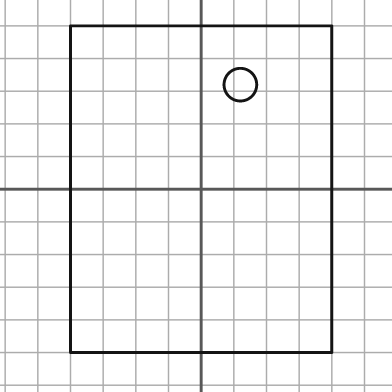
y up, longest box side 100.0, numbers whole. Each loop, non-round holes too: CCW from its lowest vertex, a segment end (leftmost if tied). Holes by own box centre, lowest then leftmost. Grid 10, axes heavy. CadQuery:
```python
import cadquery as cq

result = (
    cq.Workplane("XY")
    .moveTo(-40.0, -50.0)
    .lineTo(40.0, -50.0)
    .lineTo(40.0, 50.0)
    .lineTo(-40.0, 50.0)
    .close()
    .moveTo(12.0, 32.0)
    .circle(5.0)
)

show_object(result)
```